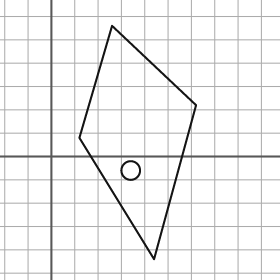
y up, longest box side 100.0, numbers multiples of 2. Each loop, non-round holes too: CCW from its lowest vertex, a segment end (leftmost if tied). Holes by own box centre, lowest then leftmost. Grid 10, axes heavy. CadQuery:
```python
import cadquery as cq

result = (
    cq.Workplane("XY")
    .moveTo(44.0, -44.0)
    .lineTo(62.0, 22.0)
    .lineTo(26.0, 56.0)
    .lineTo(12.0, 8.0)
    .close()
    .moveTo(34.0, -6.0)
    .circle(4.0)
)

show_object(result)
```